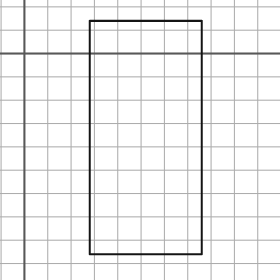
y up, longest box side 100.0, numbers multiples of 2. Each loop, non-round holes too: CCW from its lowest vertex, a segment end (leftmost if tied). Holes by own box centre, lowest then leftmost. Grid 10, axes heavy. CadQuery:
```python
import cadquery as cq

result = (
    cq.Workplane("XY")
    .moveTo(28.0, -86.0)
    .lineTo(76.0, -86.0)
    .lineTo(76.0, 14.0)
    .lineTo(28.0, 14.0)
    .close()
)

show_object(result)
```